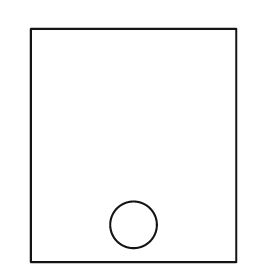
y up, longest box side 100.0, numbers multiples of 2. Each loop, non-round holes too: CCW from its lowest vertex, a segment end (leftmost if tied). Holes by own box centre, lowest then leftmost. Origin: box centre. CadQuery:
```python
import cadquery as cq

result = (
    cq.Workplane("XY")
    .moveTo(-44.0, -50.0)
    .lineTo(44.0, -50.0)
    .lineTo(44.0, 50.0)
    .lineTo(-44.0, 50.0)
    .close()
    .moveTo(0.0, -34.0)
    .circle(10.0)
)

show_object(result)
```